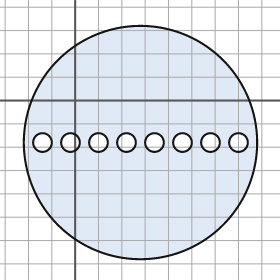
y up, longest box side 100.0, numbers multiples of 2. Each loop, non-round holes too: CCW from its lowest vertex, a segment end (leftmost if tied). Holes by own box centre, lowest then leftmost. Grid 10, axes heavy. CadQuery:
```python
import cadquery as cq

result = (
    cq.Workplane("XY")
    .moveTo(28.0, -18.0)
    .circle(50.0)
    .moveTo(-14.0, -18.0)
    .circle(4.0)
    .moveTo(-2.0, -18.0)
    .circle(4.0)
    .moveTo(10.0, -18.0)
    .circle(4.0)
    .moveTo(22.0, -18.0)
    .circle(4.0)
    .moveTo(34.0, -18.0)
    .circle(4.0)
    .moveTo(46.0, -18.0)
    .circle(4.0)
    .moveTo(58.0, -18.0)
    .circle(4.0)
    .moveTo(70.0, -18.0)
    .circle(4.0)
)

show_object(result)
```